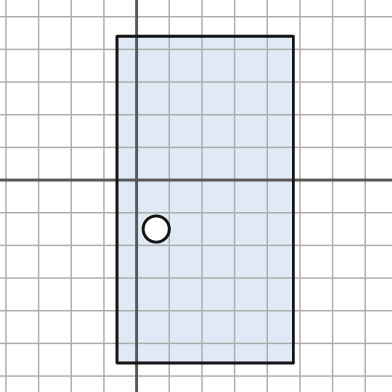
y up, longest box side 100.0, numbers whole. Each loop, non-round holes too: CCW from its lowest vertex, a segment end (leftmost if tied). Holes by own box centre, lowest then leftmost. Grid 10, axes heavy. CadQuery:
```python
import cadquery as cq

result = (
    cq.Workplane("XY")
    .moveTo(-6.0, -56.0)
    .lineTo(48.0, -56.0)
    .lineTo(48.0, 44.0)
    .lineTo(-6.0, 44.0)
    .close()
    .moveTo(6.0, -15.0)
    .circle(4.0)
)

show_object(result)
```